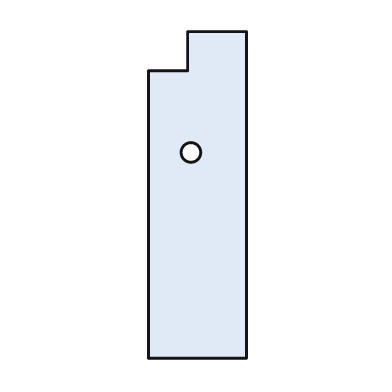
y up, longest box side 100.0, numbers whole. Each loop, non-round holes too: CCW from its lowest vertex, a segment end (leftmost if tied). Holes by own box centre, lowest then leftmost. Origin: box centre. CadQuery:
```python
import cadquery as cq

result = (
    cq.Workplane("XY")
    .moveTo(-15.0, -50.0)
    .lineTo(15.0, -50.0)
    .lineTo(15.0, 50.0)
    .lineTo(-3.0, 50.0)
    .lineTo(-3.0, 38.0)
    .lineTo(-15.0, 38.0)
    .close()
    .moveTo(-2.0, 13.0)
    .circle(3.0)
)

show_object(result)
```